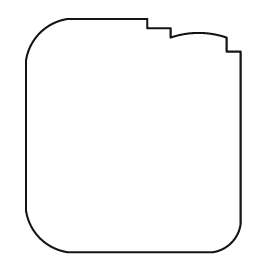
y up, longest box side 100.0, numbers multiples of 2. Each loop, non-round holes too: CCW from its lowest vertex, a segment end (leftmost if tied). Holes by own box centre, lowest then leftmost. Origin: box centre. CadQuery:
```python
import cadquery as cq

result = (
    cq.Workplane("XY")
    .moveTo(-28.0, -50.0)
    .lineTo(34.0, -50.0)
    .threePointArc((42.0, -46.0), (46.0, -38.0))
    .lineTo(46.0, 36.0)
    .lineTo(40.0, 36.0)
    .lineTo(40.0, 42.0)
    .threePointArc((28.0, 44.0), (16.0, 42.0))
    .lineTo(16.0, 46.0)
    .lineTo(6.0, 46.0)
    .lineTo(6.0, 50.0)
    .lineTo(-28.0, 50.0)
    .threePointArc((-40.0, 44.0), (-46.0, 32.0))
    .lineTo(-46.0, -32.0)
    .threePointArc((-40.0, -44.0), (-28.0, -50.0))
    .close()
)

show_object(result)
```